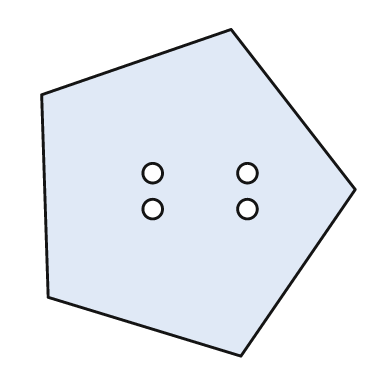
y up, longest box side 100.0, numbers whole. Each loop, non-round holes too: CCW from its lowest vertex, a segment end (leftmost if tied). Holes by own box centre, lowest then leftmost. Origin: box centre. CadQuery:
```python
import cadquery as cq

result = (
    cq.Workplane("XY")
    .moveTo(13.0, -50.0)
    .lineTo(48.0, 1.0)
    .lineTo(10.0, 50.0)
    .lineTo(-48.0, 30.0)
    .lineTo(-46.0, -32.0)
    .close()
    .moveTo(-14.0, -5.0)
    .circle(3.0)
    .moveTo(15.0, -5.0)
    .circle(3.0)
    .moveTo(-14.0, 6.0)
    .circle(3.0)
    .moveTo(15.0, 6.0)
    .circle(3.0)
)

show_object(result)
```